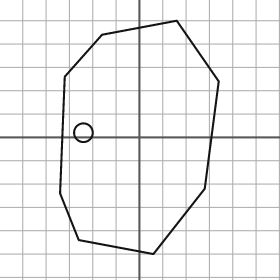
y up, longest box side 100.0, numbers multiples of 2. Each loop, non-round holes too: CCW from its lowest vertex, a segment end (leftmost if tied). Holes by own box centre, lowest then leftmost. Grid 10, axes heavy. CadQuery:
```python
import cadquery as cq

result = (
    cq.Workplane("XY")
    .moveTo(6.0, -50.0)
    .lineTo(28.0, -22.0)
    .lineTo(34.0, 24.0)
    .lineTo(16.0, 50.0)
    .lineTo(-16.0, 44.0)
    .lineTo(-32.0, 26.0)
    .lineTo(-34.0, -24.0)
    .lineTo(-26.0, -44.0)
    .close()
    .moveTo(-24.0, 2.0)
    .circle(4.0)
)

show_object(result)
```